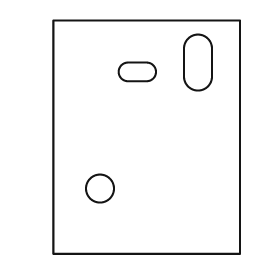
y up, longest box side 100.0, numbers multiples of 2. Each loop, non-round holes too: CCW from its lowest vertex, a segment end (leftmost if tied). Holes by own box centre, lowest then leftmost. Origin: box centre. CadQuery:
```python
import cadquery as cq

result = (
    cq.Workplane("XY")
    .moveTo(-40.0, -50.0)
    .lineTo(40.0, -50.0)
    .lineTo(40.0, 50.0)
    .lineTo(-40.0, 50.0)
    .close()
    .moveTo(-20.0, -22.0)
    .circle(6.0)
    .moveTo(-8.0, 24.0)
    .lineTo(0.0, 24.0)
    .threePointArc((4.0, 28.0), (0.0, 32.0))
    .lineTo(-8.0, 32.0)
    .threePointArc((-12.0, 28.0), (-8.0, 24.0))
    .close()
    .moveTo(16.0, 26.0)
    .threePointArc((22.0, 20.0), (28.0, 26.0))
    .lineTo(28.0, 38.0)
    .threePointArc((22.0, 44.0), (16.0, 38.0))
    .close()
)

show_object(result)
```